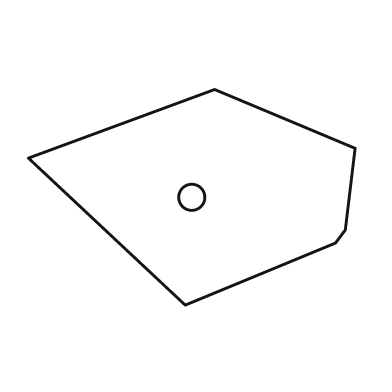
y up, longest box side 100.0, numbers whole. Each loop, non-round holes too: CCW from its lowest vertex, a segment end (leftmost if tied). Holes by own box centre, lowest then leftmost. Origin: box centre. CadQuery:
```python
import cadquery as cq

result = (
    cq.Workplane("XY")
    .moveTo(-2.0, -33.0)
    .lineTo(44.0, -14.0)
    .lineTo(47.0, -10.0)
    .lineTo(50.0, 15.0)
    .lineTo(7.0, 33.0)
    .lineTo(-50.0, 12.0)
    .close()
    .moveTo(0.0, 0.0)
    .circle(4.0)
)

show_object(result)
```